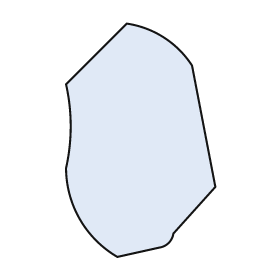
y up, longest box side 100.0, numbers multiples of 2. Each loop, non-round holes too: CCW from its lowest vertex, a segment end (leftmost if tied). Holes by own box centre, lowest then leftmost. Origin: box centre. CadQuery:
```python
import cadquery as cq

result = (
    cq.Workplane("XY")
    .moveTo(-10.0, -50.0)
    .lineTo(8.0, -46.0)
    .threePointArc((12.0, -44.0), (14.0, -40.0))
    .lineTo(32.0, -20.0)
    .lineTo(22.0, 32.0)
    .threePointArc((10.0, 44.0), (-6.0, 50.0))
    .lineTo(-32.0, 24.0)
    .threePointArc((-30.0, 6.0), (-32.0, -12.0))
    .threePointArc((-26.0, -34.0), (-10.0, -50.0))
    .close()
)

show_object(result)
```